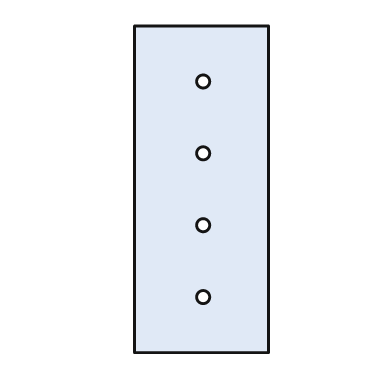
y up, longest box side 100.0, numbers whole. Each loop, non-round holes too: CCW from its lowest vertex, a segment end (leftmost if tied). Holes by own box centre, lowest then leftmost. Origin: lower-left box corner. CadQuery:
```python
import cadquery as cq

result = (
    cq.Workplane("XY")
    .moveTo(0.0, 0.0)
    .lineTo(41.0, 0.0)
    .lineTo(41.0, 100.0)
    .lineTo(0.0, 100.0)
    .close()
    .moveTo(21.0, 17.0)
    .circle(2.0)
    .moveTo(21.0, 39.0)
    .circle(2.0)
    .moveTo(21.0, 61.0)
    .circle(2.0)
    .moveTo(21.0, 83.0)
    .circle(2.0)
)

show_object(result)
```